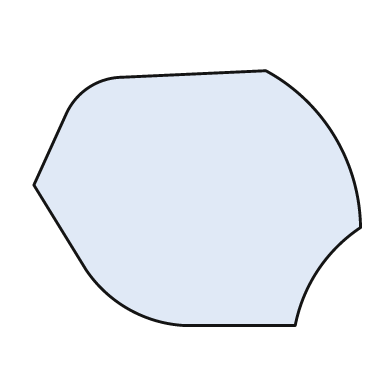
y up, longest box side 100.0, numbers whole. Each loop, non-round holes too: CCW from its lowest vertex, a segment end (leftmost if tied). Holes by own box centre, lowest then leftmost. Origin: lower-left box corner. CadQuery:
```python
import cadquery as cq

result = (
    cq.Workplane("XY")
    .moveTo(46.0, 0.0)
    .lineTo(80.0, 0.0)
    .threePointArc((87.0, 17.0), (100.0, 30.0))
    .threePointArc((92.0, 58.0), (71.0, 78.0))
    .lineTo(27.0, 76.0)
    .threePointArc((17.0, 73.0), (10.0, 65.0))
    .lineTo(0.0, 43.0)
    .lineTo(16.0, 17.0)
    .threePointArc((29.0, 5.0), (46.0, 0.0))
    .close()
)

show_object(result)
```